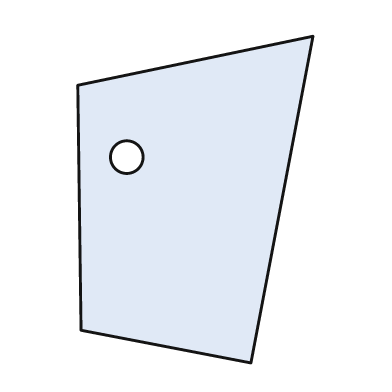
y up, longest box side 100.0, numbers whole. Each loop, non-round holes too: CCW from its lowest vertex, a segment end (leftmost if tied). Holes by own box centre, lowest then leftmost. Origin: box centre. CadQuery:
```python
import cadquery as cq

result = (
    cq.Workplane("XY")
    .moveTo(17.0, -50.0)
    .lineTo(36.0, 50.0)
    .lineTo(-36.0, 35.0)
    .lineTo(-35.0, -40.0)
    .close()
    .moveTo(-21.0, 13.0)
    .circle(5.0)
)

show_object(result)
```